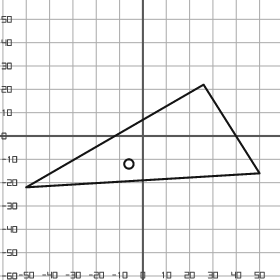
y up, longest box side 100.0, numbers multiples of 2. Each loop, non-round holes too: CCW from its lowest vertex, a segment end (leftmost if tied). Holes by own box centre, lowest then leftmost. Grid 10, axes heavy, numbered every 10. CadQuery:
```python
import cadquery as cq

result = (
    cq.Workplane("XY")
    .moveTo(-50.0, -22.0)
    .lineTo(50.0, -16.0)
    .lineTo(26.0, 22.0)
    .close()
    .moveTo(-6.0, -12.0)
    .circle(2.0)
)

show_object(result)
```